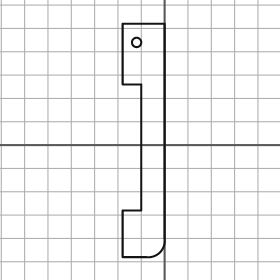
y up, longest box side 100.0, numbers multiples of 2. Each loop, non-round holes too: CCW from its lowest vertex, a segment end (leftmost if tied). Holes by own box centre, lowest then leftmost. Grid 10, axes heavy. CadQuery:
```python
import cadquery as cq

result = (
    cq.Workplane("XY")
    .moveTo(-18.0, -48.0)
    .lineTo(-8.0, -48.0)
    .threePointArc((-2.0, -46.0), (0.0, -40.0))
    .lineTo(0.0, 52.0)
    .lineTo(-18.0, 52.0)
    .lineTo(-18.0, 26.0)
    .lineTo(-10.0, 26.0)
    .lineTo(-10.0, -28.0)
    .lineTo(-18.0, -28.0)
    .close()
    .moveTo(-12.0, 44.0)
    .circle(2.0)
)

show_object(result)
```